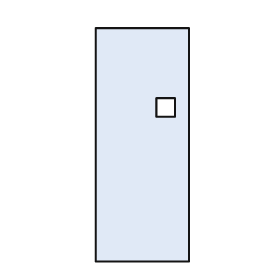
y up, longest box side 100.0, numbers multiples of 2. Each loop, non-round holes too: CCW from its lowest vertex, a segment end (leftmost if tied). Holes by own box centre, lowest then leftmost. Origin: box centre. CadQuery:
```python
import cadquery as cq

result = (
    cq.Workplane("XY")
    .moveTo(-20.0, -50.0)
    .lineTo(20.0, -50.0)
    .lineTo(20.0, 50.0)
    .lineTo(-20.0, 50.0)
    .close()
    .moveTo(6.0, 12.0)
    .lineTo(14.0, 12.0)
    .lineTo(14.0, 20.0)
    .lineTo(6.0, 20.0)
    .close()
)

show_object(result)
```